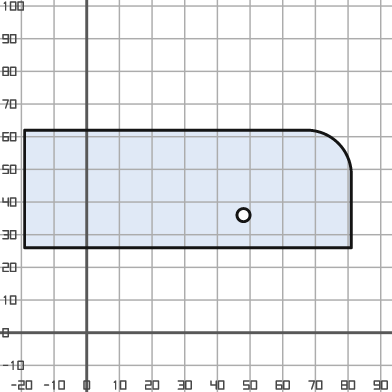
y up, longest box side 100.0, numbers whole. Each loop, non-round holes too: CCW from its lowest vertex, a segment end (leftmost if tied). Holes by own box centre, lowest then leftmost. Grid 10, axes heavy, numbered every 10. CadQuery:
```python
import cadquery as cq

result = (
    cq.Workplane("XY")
    .moveTo(-19.0, 26.0)
    .lineTo(81.0, 26.0)
    .lineTo(81.0, 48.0)
    .threePointArc((77.0, 58.0), (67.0, 62.0))
    .lineTo(-19.0, 62.0)
    .close()
    .moveTo(48.0, 36.0)
    .circle(2.0)
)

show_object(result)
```